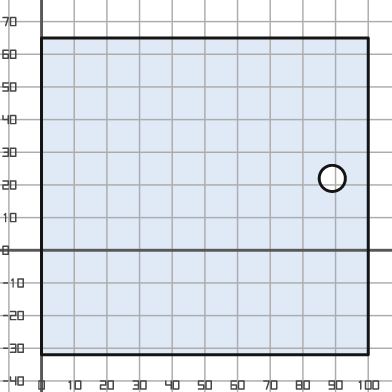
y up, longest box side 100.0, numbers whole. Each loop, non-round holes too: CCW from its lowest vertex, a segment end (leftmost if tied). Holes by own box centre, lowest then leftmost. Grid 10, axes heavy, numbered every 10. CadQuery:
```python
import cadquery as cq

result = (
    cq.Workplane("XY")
    .moveTo(0.0, -32.0)
    .lineTo(100.0, -32.0)
    .lineTo(100.0, 65.0)
    .lineTo(0.0, 65.0)
    .close()
    .moveTo(89.0, 22.0)
    .circle(4.0)
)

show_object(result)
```